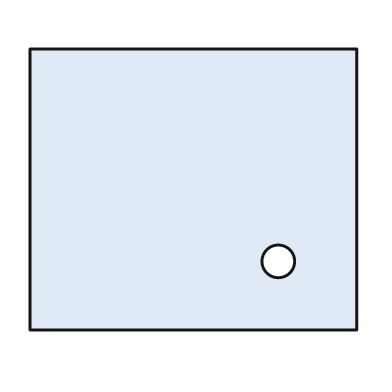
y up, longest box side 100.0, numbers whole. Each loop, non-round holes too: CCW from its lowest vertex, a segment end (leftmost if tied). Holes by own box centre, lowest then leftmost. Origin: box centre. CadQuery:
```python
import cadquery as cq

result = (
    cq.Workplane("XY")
    .moveTo(-50.0, -43.0)
    .lineTo(50.0, -43.0)
    .lineTo(50.0, 43.0)
    .lineTo(-50.0, 43.0)
    .close()
    .moveTo(26.0, -22.0)
    .circle(5.0)
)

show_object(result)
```